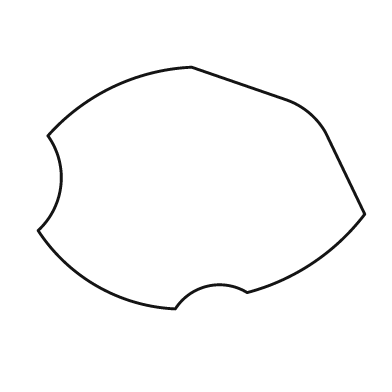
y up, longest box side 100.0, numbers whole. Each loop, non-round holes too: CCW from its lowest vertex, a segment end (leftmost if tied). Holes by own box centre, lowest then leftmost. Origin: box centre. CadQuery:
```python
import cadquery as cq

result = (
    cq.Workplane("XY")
    .moveTo(-8.0, -37.0)
    .threePointArc((2.0, -30.0), (14.0, -32.0))
    .threePointArc((34.0, -23.0), (50.0, -8.0))
    .lineTo(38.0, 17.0)
    .threePointArc((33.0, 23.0), (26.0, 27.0))
    .lineTo(-3.0, 37.0)
    .threePointArc((-27.0, 31.0), (-47.0, 16.0))
    .threePointArc((-43.0, 1.0), (-50.0, -13.0))
    .threePointArc((-32.0, -30.0), (-8.0, -37.0))
    .close()
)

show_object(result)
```